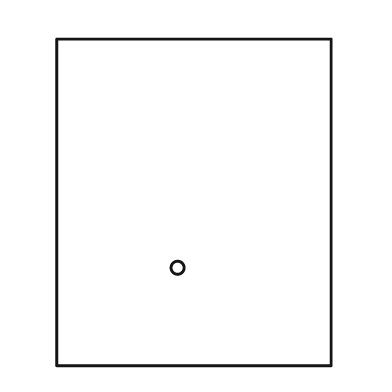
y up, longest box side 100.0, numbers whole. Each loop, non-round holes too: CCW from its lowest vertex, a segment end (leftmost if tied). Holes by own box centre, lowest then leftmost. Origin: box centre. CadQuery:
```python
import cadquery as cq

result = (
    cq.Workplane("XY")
    .moveTo(-42.0, -50.0)
    .lineTo(42.0, -50.0)
    .lineTo(42.0, 50.0)
    .lineTo(-42.0, 50.0)
    .close()
    .moveTo(-5.0, -20.0)
    .circle(2.0)
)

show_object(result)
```